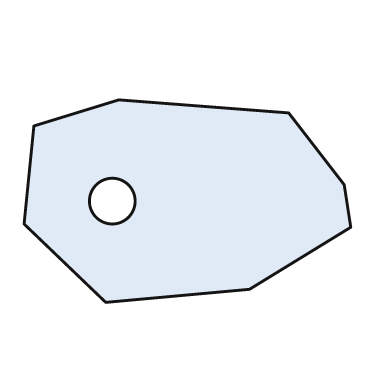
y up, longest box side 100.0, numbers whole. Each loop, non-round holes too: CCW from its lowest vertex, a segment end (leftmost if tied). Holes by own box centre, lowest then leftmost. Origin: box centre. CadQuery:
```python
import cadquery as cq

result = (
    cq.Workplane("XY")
    .moveTo(-25.0, -31.0)
    .lineTo(19.0, -27.0)
    .lineTo(50.0, -8.0)
    .lineTo(48.0, 5.0)
    .lineTo(31.0, 27.0)
    .lineTo(-21.0, 31.0)
    .lineTo(-47.0, 23.0)
    .lineTo(-50.0, -7.0)
    .close()
    .moveTo(-23.0, 0.0)
    .circle(7.0)
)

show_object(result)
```